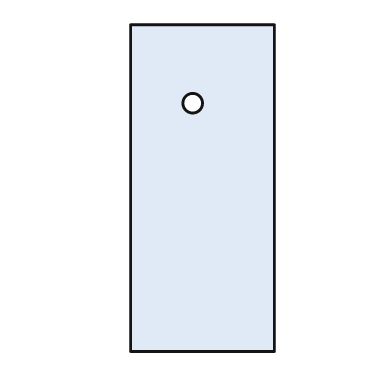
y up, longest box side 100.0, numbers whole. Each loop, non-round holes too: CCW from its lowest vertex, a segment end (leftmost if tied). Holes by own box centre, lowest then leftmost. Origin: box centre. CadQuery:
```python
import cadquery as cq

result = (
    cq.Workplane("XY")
    .moveTo(-22.0, -50.0)
    .lineTo(22.0, -50.0)
    .lineTo(22.0, 50.0)
    .lineTo(-22.0, 50.0)
    .close()
    .moveTo(-3.0, 26.0)
    .circle(3.0)
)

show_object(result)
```